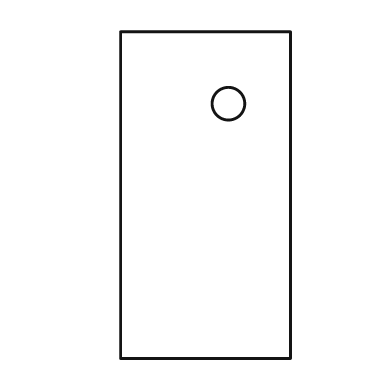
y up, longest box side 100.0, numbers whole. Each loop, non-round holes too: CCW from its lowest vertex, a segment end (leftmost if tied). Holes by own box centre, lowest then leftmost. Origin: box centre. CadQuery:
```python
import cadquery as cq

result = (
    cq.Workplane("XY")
    .moveTo(-26.0, -50.0)
    .lineTo(26.0, -50.0)
    .lineTo(26.0, 50.0)
    .lineTo(-26.0, 50.0)
    .close()
    .moveTo(7.0, 28.0)
    .circle(5.0)
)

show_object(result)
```